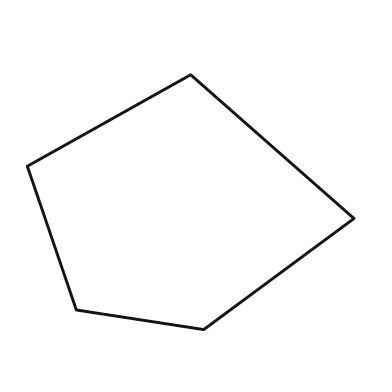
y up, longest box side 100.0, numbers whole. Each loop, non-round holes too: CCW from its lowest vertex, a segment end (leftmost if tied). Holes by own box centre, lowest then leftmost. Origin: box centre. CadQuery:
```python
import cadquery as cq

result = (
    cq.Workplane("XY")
    .moveTo(4.0, -39.0)
    .lineTo(50.0, -5.0)
    .lineTo(0.0, 39.0)
    .lineTo(-50.0, 11.0)
    .lineTo(-35.0, -33.0)
    .close()
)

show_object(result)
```